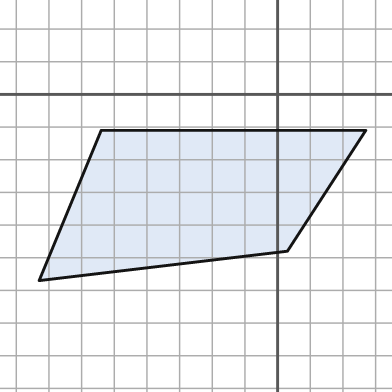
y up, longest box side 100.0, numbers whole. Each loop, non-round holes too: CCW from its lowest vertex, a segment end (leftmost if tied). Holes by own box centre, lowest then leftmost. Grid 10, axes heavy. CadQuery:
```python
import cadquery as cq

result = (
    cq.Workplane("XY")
    .moveTo(-73.0, -57.0)
    .lineTo(3.0, -48.0)
    .lineTo(27.0, -11.0)
    .lineTo(-54.0, -11.0)
    .close()
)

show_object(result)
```